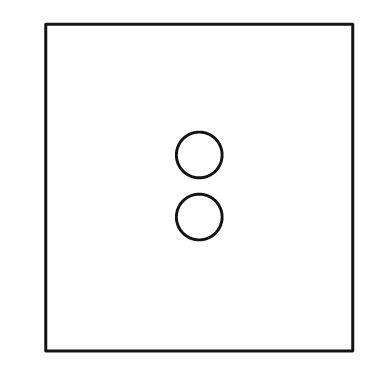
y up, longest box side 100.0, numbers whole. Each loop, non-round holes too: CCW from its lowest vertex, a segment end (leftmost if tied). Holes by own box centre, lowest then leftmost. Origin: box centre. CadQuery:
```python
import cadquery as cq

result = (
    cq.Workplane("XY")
    .moveTo(-47.0, -50.0)
    .lineTo(47.0, -50.0)
    .lineTo(47.0, 50.0)
    .lineTo(-47.0, 50.0)
    .close()
    .moveTo(0.0, -9.0)
    .circle(7.0)
    .moveTo(0.0, 10.0)
    .circle(7.0)
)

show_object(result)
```